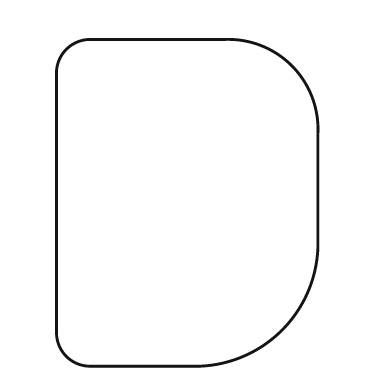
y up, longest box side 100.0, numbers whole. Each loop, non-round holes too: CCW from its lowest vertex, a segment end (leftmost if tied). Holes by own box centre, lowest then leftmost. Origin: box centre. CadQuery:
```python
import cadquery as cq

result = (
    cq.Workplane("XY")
    .moveTo(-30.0, -50.0)
    .lineTo(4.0, -50.0)
    .threePointArc((29.0, -39.0), (40.0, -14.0))
    .lineTo(40.0, 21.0)
    .threePointArc((32.0, 42.0), (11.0, 50.0))
    .lineTo(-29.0, 50.0)
    .threePointArc((-37.0, 47.0), (-40.0, 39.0))
    .lineTo(-40.0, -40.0)
    .threePointArc((-37.0, -47.0), (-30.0, -50.0))
    .close()
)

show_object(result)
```